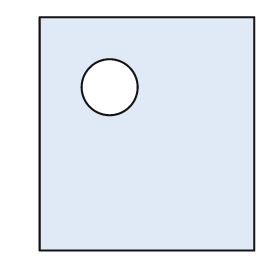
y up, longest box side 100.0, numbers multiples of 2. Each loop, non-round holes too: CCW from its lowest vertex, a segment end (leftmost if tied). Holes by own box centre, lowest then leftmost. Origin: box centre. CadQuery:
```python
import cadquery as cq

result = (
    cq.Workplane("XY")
    .moveTo(-46.0, -50.0)
    .lineTo(46.0, -50.0)
    .lineTo(46.0, 50.0)
    .lineTo(-46.0, 50.0)
    .close()
    .moveTo(-16.0, 20.0)
    .circle(12.0)
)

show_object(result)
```